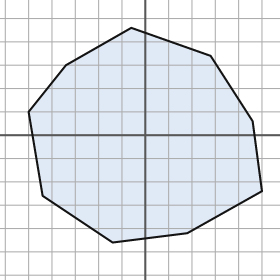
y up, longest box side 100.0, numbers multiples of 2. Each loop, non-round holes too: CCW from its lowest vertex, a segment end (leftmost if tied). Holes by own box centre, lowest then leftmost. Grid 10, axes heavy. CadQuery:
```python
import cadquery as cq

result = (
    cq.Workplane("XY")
    .moveTo(-14.0, -46.0)
    .lineTo(18.0, -42.0)
    .lineTo(50.0, -24.0)
    .lineTo(46.0, 6.0)
    .lineTo(28.0, 34.0)
    .lineTo(-6.0, 46.0)
    .lineTo(-34.0, 30.0)
    .lineTo(-50.0, 10.0)
    .lineTo(-44.0, -26.0)
    .close()
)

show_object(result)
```